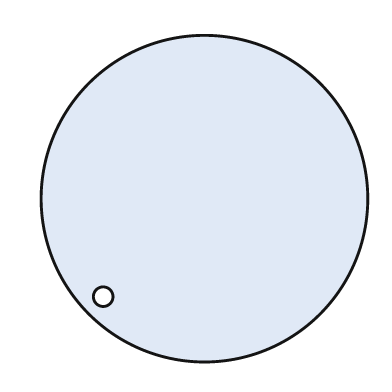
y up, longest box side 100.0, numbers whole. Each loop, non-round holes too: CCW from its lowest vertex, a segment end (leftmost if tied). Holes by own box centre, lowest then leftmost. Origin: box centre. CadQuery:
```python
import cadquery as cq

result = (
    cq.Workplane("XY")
    .moveTo(0.0, 0.0)
    .circle(50.0)
    .moveTo(-31.0, -30.0)
    .circle(3.0)
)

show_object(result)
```